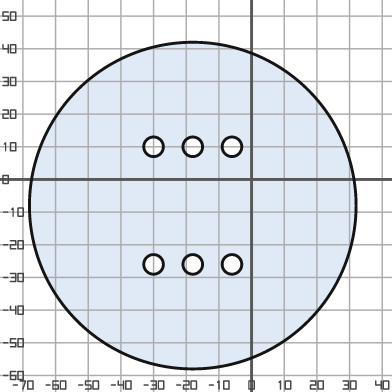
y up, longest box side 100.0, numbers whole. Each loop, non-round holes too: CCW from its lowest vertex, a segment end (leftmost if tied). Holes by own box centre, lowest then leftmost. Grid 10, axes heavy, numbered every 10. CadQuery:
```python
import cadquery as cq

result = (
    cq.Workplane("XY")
    .moveTo(-18.0, -8.0)
    .circle(50.0)
    .moveTo(-30.0, -26.0)
    .circle(3.0)
    .moveTo(-18.0, -26.0)
    .circle(3.0)
    .moveTo(-6.0, -26.0)
    .circle(3.0)
    .moveTo(-30.0, 10.0)
    .circle(3.0)
    .moveTo(-18.0, 10.0)
    .circle(3.0)
    .moveTo(-6.0, 10.0)
    .circle(3.0)
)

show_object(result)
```